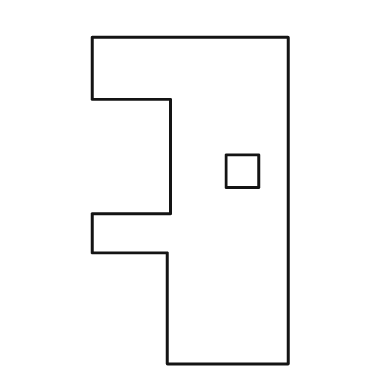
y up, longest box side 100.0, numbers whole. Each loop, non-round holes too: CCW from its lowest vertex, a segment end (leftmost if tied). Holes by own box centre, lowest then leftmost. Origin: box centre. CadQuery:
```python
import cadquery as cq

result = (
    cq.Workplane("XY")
    .moveTo(-7.0, -50.0)
    .lineTo(30.0, -50.0)
    .lineTo(30.0, 50.0)
    .lineTo(-30.0, 50.0)
    .lineTo(-30.0, 31.0)
    .lineTo(-6.0, 31.0)
    .lineTo(-6.0, -4.0)
    .lineTo(-30.0, -4.0)
    .lineTo(-30.0, -16.0)
    .lineTo(-7.0, -16.0)
    .close()
    .moveTo(11.0, 4.0)
    .lineTo(21.0, 4.0)
    .lineTo(21.0, 14.0)
    .lineTo(11.0, 14.0)
    .close()
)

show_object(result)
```